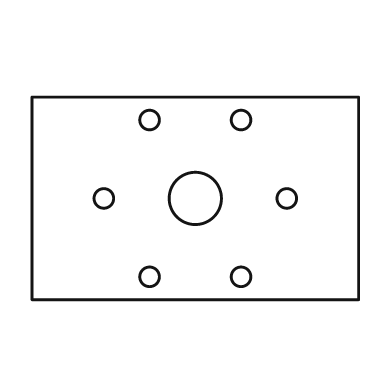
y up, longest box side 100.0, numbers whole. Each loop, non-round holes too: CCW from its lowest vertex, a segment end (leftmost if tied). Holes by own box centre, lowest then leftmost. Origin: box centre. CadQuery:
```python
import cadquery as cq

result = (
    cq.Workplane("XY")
    .moveTo(-50.0, -31.0)
    .lineTo(50.0, -31.0)
    .lineTo(50.0, 31.0)
    .lineTo(-50.0, 31.0)
    .close()
    .moveTo(-14.0, -24.0)
    .circle(3.0)
    .moveTo(14.0, -24.0)
    .circle(3.0)
    .moveTo(-28.0, 0.0)
    .circle(3.0)
    .moveTo(0.0, 0.0)
    .circle(8.0)
    .moveTo(28.0, 0.0)
    .circle(3.0)
    .moveTo(-14.0, 24.0)
    .circle(3.0)
    .moveTo(14.0, 24.0)
    .circle(3.0)
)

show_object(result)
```